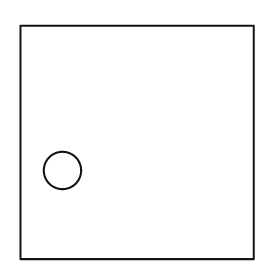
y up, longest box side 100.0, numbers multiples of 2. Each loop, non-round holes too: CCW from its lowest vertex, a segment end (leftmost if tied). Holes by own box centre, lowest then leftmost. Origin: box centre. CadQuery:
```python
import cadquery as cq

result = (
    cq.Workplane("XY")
    .moveTo(-50.0, -50.0)
    .lineTo(50.0, -50.0)
    .lineTo(50.0, 50.0)
    .lineTo(-50.0, 50.0)
    .close()
    .moveTo(-32.0, -12.0)
    .circle(8.0)
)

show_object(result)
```